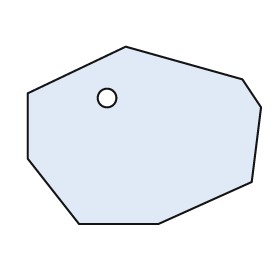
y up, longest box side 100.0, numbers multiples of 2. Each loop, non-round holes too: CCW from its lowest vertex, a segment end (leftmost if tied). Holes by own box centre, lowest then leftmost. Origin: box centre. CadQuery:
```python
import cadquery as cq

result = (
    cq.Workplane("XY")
    .moveTo(-28.0, -38.0)
    .lineTo(6.0, -38.0)
    .lineTo(46.0, -20.0)
    .lineTo(50.0, 12.0)
    .lineTo(42.0, 24.0)
    .lineTo(-8.0, 38.0)
    .lineTo(-50.0, 18.0)
    .lineTo(-50.0, -10.0)
    .close()
    .moveTo(-16.0, 16.0)
    .circle(4.0)
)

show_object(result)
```